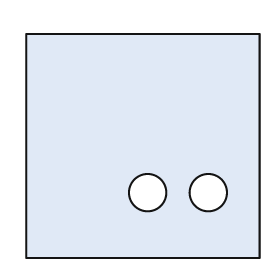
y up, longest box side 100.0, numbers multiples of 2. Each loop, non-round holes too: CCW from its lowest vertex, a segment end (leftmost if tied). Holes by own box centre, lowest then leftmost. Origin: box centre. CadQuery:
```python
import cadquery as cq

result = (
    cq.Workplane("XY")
    .moveTo(-50.0, -48.0)
    .lineTo(50.0, -48.0)
    .lineTo(50.0, 48.0)
    .lineTo(-50.0, 48.0)
    .close()
    .moveTo(2.0, -20.0)
    .circle(8.0)
    .moveTo(28.0, -20.0)
    .circle(8.0)
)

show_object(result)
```